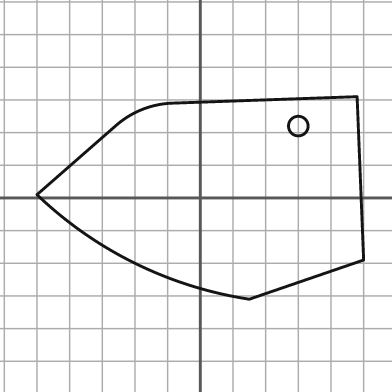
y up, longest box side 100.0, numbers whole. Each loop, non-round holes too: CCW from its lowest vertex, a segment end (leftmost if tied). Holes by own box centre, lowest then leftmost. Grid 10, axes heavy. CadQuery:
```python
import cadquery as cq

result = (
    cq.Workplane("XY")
    .moveTo(15.0, -31.0)
    .lineTo(50.0, -19.0)
    .lineTo(48.0, 31.0)
    .lineTo(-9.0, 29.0)
    .threePointArc((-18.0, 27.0), (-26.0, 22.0))
    .lineTo(-50.0, 1.0)
    .threePointArc((-20.0, -20.0), (15.0, -31.0))
    .close()
    .moveTo(30.0, 22.0)
    .circle(3.0)
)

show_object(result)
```